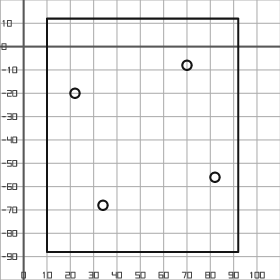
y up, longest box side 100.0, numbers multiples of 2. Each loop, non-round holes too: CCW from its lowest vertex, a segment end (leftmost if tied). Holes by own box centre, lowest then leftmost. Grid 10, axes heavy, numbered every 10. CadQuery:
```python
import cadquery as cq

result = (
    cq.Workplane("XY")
    .moveTo(10.0, -88.0)
    .lineTo(92.0, -88.0)
    .lineTo(92.0, 12.0)
    .lineTo(10.0, 12.0)
    .close()
    .moveTo(34.0, -68.0)
    .circle(2.0)
    .moveTo(82.0, -56.0)
    .circle(2.0)
    .moveTo(22.0, -20.0)
    .circle(2.0)
    .moveTo(70.0, -8.0)
    .circle(2.0)
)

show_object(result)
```